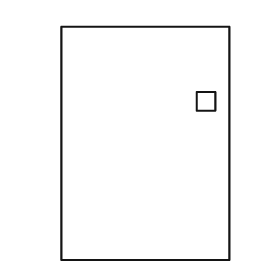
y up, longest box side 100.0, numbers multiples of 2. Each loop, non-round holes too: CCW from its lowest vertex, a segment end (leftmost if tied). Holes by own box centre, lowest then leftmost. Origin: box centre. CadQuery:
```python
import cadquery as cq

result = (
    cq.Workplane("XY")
    .moveTo(-36.0, -50.0)
    .lineTo(36.0, -50.0)
    .lineTo(36.0, 50.0)
    .lineTo(-36.0, 50.0)
    .close()
    .moveTo(22.0, 14.0)
    .lineTo(30.0, 14.0)
    .lineTo(30.0, 22.0)
    .lineTo(22.0, 22.0)
    .close()
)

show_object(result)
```